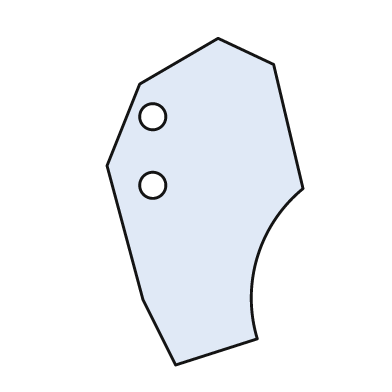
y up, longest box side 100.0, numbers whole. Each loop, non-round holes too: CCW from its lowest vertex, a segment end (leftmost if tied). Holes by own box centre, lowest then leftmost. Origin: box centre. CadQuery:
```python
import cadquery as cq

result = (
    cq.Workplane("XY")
    .moveTo(-9.0, -50.0)
    .lineTo(16.0, -42.0)
    .threePointArc((16.0, -17.0), (30.0, 4.0))
    .lineTo(21.0, 42.0)
    .lineTo(4.0, 50.0)
    .lineTo(-20.0, 36.0)
    .lineTo(-30.0, 11.0)
    .lineTo(-19.0, -30.0)
    .close()
    .moveTo(-16.0, 5.0)
    .circle(4.0)
    .moveTo(-16.0, 26.0)
    .circle(4.0)
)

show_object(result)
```